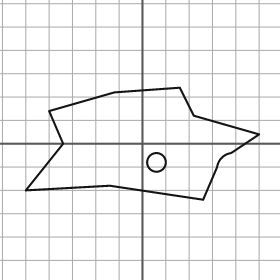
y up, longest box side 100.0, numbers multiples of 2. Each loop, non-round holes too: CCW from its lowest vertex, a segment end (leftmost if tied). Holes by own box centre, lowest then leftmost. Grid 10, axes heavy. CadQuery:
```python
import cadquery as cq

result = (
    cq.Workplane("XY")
    .moveTo(26.0, -24.0)
    .lineTo(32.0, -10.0)
    .threePointArc((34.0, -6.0), (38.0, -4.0))
    .lineTo(50.0, 4.0)
    .lineTo(22.0, 12.0)
    .lineTo(16.0, 24.0)
    .lineTo(-12.0, 22.0)
    .lineTo(-40.0, 14.0)
    .lineTo(-34.0, 0.0)
    .lineTo(-50.0, -20.0)
    .lineTo(-14.0, -18.0)
    .close()
    .moveTo(6.0, -8.0)
    .circle(4.0)
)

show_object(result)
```